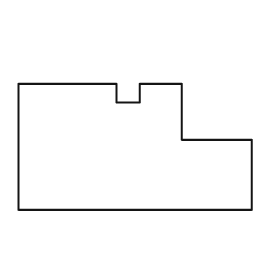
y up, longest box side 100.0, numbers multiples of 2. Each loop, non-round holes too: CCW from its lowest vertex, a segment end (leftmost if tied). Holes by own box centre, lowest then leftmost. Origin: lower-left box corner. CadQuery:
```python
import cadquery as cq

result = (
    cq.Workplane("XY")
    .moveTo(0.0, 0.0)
    .lineTo(100.0, 0.0)
    .lineTo(100.0, 30.0)
    .lineTo(70.0, 30.0)
    .lineTo(70.0, 54.0)
    .lineTo(52.0, 54.0)
    .lineTo(52.0, 46.0)
    .lineTo(42.0, 46.0)
    .lineTo(42.0, 54.0)
    .lineTo(0.0, 54.0)
    .close()
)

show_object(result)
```